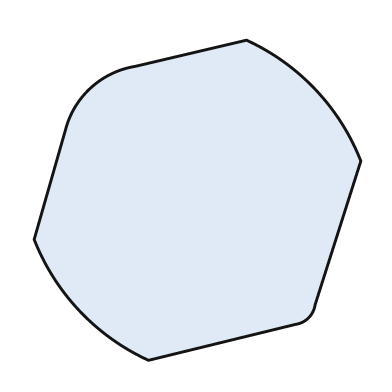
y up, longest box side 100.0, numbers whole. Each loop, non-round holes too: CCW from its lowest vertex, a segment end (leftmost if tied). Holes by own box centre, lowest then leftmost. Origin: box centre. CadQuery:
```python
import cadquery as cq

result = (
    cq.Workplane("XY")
    .moveTo(-15.0, -49.0)
    .lineTo(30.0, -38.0)
    .threePointArc((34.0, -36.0), (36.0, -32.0))
    .lineTo(50.0, 12.0)
    .threePointArc((36.0, 34.0), (15.0, 49.0))
    .lineTo(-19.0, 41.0)
    .threePointArc((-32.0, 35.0), (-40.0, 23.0))
    .lineTo(-50.0, -12.0)
    .threePointArc((-36.0, -34.0), (-15.0, -49.0))
    .close()
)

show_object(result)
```